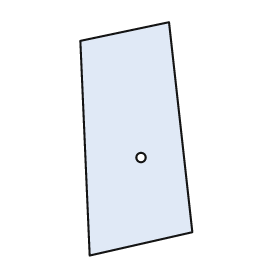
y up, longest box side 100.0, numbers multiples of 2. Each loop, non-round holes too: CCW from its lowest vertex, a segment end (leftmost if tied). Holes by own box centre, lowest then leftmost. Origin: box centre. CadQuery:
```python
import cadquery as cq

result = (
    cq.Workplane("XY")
    .moveTo(-20.0, -50.0)
    .lineTo(24.0, -40.0)
    .lineTo(14.0, 50.0)
    .lineTo(-24.0, 42.0)
    .close()
    .moveTo(2.0, -8.0)
    .circle(2.0)
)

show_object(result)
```